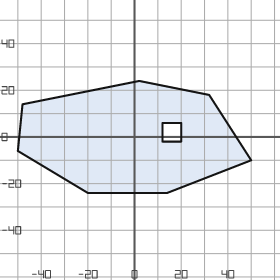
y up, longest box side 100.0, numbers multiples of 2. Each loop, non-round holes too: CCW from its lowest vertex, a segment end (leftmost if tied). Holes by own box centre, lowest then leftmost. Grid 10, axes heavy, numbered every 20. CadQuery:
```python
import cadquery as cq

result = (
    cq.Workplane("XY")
    .moveTo(-20.0, -24.0)
    .lineTo(14.0, -24.0)
    .lineTo(50.0, -10.0)
    .lineTo(32.0, 18.0)
    .lineTo(2.0, 24.0)
    .lineTo(-48.0, 14.0)
    .lineTo(-50.0, -6.0)
    .close()
    .moveTo(12.0, -2.0)
    .lineTo(20.0, -2.0)
    .lineTo(20.0, 6.0)
    .lineTo(12.0, 6.0)
    .close()
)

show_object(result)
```